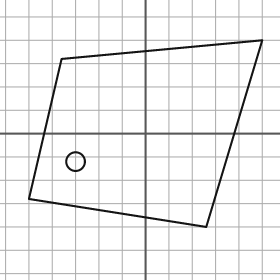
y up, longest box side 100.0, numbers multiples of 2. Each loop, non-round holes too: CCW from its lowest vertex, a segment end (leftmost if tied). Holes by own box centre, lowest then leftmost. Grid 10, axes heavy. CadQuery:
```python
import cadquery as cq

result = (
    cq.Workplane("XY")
    .moveTo(26.0, -40.0)
    .lineTo(50.0, 40.0)
    .lineTo(-36.0, 32.0)
    .lineTo(-50.0, -28.0)
    .close()
    .moveTo(-30.0, -12.0)
    .circle(4.0)
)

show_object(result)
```